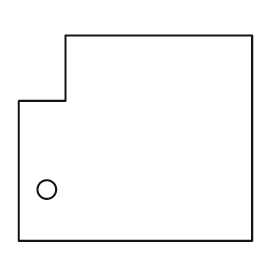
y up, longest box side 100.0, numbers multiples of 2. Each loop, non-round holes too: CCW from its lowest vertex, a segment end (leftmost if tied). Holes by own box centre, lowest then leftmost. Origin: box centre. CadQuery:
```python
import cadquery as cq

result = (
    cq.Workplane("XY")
    .moveTo(-50.0, -44.0)
    .lineTo(50.0, -44.0)
    .lineTo(50.0, 44.0)
    .lineTo(-30.0, 44.0)
    .lineTo(-30.0, 16.0)
    .lineTo(-50.0, 16.0)
    .close()
    .moveTo(-38.0, -22.0)
    .circle(4.0)
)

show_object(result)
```